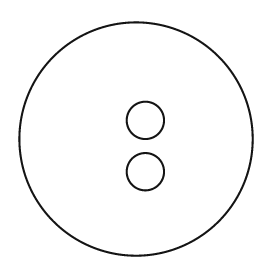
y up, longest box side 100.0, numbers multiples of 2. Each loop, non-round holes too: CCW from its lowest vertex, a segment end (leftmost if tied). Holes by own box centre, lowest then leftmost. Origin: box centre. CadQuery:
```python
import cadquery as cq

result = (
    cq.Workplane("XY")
    .moveTo(0.0, 0.0)
    .circle(50.0)
    .moveTo(4.0, -14.0)
    .circle(8.0)
    .moveTo(4.0, 8.0)
    .circle(8.0)
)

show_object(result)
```